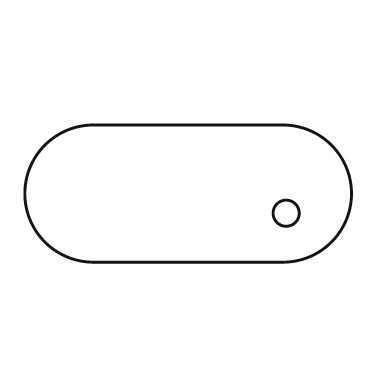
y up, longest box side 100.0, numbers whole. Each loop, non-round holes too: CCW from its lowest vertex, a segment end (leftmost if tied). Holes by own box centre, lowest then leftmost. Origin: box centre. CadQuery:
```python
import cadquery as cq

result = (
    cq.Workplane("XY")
    .moveTo(-29.0, -21.0)
    .lineTo(29.0, -21.0)
    .threePointArc((50.0, 0.0), (29.0, 21.0))
    .lineTo(-29.0, 21.0)
    .threePointArc((-50.0, 0.0), (-29.0, -21.0))
    .close()
    .moveTo(30.0, -6.0)
    .circle(4.0)
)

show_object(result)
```